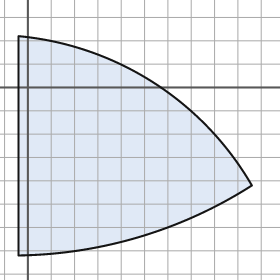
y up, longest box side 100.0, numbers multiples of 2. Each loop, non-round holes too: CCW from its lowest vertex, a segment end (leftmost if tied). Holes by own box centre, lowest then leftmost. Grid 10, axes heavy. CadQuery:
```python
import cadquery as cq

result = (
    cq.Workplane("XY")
    .moveTo(-4.0, -72.0)
    .threePointArc((48.0, -64.0), (96.0, -42.0))
    .threePointArc((54.0, 2.0), (-4.0, 22.0))
    .close()
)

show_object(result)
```